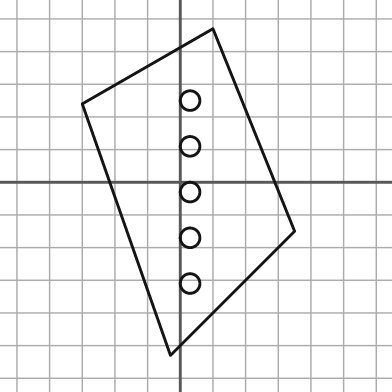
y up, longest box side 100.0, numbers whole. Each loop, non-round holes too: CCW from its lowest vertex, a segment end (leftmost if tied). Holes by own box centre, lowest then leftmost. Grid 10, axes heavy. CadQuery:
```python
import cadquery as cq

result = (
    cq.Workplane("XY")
    .moveTo(-3.0, -53.0)
    .lineTo(35.0, -15.0)
    .lineTo(10.0, 47.0)
    .lineTo(-30.0, 24.0)
    .close()
    .moveTo(3.0, -31.0)
    .circle(3.0)
    .moveTo(3.0, -17.0)
    .circle(3.0)
    .moveTo(3.0, -3.0)
    .circle(3.0)
    .moveTo(3.0, 11.0)
    .circle(3.0)
    .moveTo(3.0, 25.0)
    .circle(3.0)
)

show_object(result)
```